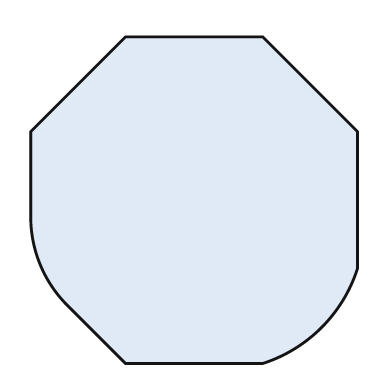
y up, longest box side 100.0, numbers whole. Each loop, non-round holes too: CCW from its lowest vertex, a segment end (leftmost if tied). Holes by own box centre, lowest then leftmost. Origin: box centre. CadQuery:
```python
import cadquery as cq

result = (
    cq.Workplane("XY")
    .moveTo(-21.0, -50.0)
    .lineTo(21.0, -50.0)
    .threePointArc((39.0, -39.0), (50.0, -21.0))
    .lineTo(50.0, 21.0)
    .lineTo(21.0, 50.0)
    .lineTo(-21.0, 50.0)
    .lineTo(-50.0, 21.0)
    .lineTo(-50.0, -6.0)
    .threePointArc((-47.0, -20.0), (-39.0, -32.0))
    .close()
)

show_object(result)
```